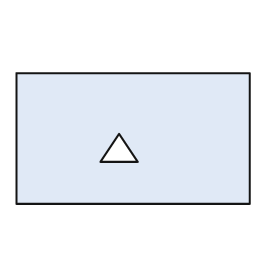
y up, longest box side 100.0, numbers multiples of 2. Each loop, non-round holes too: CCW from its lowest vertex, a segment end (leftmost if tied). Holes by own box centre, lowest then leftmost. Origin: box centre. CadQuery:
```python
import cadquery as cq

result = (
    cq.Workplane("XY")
    .moveTo(-50.0, -28.0)
    .lineTo(50.0, -28.0)
    .lineTo(50.0, 28.0)
    .lineTo(-50.0, 28.0)
    .close()
    .moveTo(-14.0, -10.0)
    .lineTo(2.0, -10.0)
    .lineTo(-6.0, 2.0)
    .close()
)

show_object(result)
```